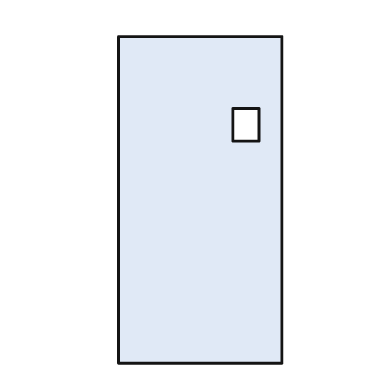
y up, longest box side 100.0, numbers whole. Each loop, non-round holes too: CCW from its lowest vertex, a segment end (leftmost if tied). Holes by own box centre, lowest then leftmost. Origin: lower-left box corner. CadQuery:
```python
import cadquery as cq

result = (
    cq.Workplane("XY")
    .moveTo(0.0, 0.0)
    .lineTo(50.0, 0.0)
    .lineTo(50.0, 100.0)
    .lineTo(0.0, 100.0)
    .close()
    .moveTo(35.0, 68.0)
    .lineTo(43.0, 68.0)
    .lineTo(43.0, 78.0)
    .lineTo(35.0, 78.0)
    .close()
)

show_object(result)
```